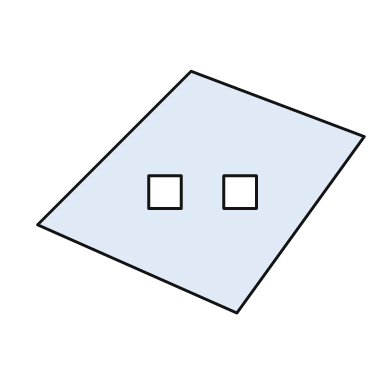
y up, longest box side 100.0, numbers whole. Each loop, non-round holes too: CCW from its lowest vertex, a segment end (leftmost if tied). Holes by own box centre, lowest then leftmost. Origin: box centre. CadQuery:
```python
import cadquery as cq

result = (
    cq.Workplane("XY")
    .moveTo(11.0, -37.0)
    .lineTo(50.0, 17.0)
    .lineTo(-3.0, 37.0)
    .lineTo(-50.0, -10.0)
    .close()
    .moveTo(-16.0, -5.0)
    .lineTo(-6.0, -5.0)
    .lineTo(-6.0, 5.0)
    .lineTo(-16.0, 5.0)
    .close()
    .moveTo(7.0, -5.0)
    .lineTo(17.0, -5.0)
    .lineTo(17.0, 5.0)
    .lineTo(7.0, 5.0)
    .close()
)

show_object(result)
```